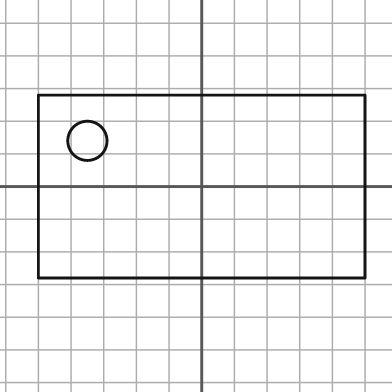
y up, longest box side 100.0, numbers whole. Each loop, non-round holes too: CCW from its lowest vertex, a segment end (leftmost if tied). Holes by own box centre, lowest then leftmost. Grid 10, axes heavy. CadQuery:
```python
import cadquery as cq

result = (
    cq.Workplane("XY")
    .moveTo(-50.0, -28.0)
    .lineTo(50.0, -28.0)
    .lineTo(50.0, 28.0)
    .lineTo(-50.0, 28.0)
    .close()
    .moveTo(-35.0, 14.0)
    .circle(6.0)
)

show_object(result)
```